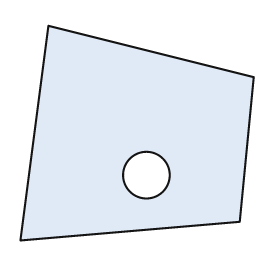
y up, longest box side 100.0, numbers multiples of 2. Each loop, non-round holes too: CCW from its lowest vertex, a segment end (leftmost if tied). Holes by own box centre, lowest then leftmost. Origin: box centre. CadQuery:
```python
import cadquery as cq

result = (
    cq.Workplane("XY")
    .moveTo(-50.0, -46.0)
    .lineTo(44.0, -38.0)
    .lineTo(50.0, 24.0)
    .lineTo(-38.0, 46.0)
    .close()
    .moveTo(4.0, -18.0)
    .circle(10.0)
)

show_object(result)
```